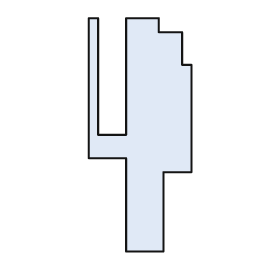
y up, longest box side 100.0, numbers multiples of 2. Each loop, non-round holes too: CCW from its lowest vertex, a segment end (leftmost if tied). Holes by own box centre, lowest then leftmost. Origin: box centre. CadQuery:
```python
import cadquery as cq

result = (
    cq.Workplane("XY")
    .moveTo(-6.0, -50.0)
    .lineTo(10.0, -50.0)
    .lineTo(10.0, -16.0)
    .lineTo(22.0, -16.0)
    .lineTo(22.0, 30.0)
    .lineTo(18.0, 30.0)
    .lineTo(18.0, 44.0)
    .lineTo(8.0, 44.0)
    .lineTo(8.0, 50.0)
    .lineTo(-6.0, 50.0)
    .lineTo(-6.0, 0.0)
    .lineTo(-18.0, 0.0)
    .lineTo(-18.0, 50.0)
    .lineTo(-22.0, 50.0)
    .lineTo(-22.0, -10.0)
    .lineTo(-6.0, -10.0)
    .close()
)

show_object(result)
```